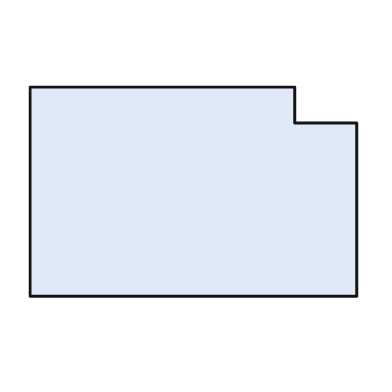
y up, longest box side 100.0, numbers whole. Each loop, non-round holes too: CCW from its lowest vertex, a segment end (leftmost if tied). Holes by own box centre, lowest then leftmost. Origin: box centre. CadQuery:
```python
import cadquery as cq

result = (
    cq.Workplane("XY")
    .moveTo(-50.0, -32.0)
    .lineTo(50.0, -32.0)
    .lineTo(50.0, 21.0)
    .lineTo(31.0, 21.0)
    .lineTo(31.0, 32.0)
    .lineTo(-50.0, 32.0)
    .close()
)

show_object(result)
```